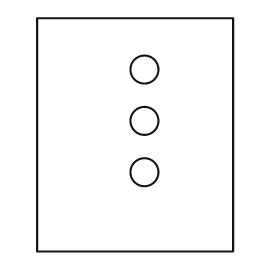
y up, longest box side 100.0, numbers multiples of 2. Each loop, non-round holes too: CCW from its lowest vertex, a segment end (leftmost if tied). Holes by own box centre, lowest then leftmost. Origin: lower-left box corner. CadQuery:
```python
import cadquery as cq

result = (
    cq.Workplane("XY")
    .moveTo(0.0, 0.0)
    .lineTo(84.0, 0.0)
    .lineTo(84.0, 100.0)
    .lineTo(0.0, 100.0)
    .close()
    .moveTo(46.0, 34.0)
    .circle(6.0)
    .moveTo(46.0, 56.0)
    .circle(6.0)
    .moveTo(46.0, 78.0)
    .circle(6.0)
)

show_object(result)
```